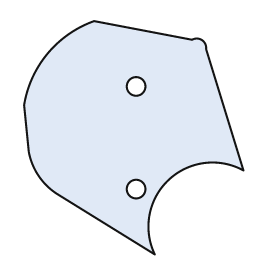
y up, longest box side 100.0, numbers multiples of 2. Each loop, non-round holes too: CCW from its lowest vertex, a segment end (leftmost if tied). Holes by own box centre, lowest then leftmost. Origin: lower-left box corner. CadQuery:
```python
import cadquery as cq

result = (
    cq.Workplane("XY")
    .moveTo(56.0, 0.0)
    .threePointArc((62.0, 32.0), (94.0, 36.0))
    .lineTo(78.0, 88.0)
    .threePointArc((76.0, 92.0), (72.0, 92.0))
    .lineTo(30.0, 100.0)
    .threePointArc((10.0, 86.0), (0.0, 64.0))
    .lineTo(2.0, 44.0)
    .threePointArc((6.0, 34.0), (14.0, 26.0))
    .close()
    .moveTo(48.0, 28.0)
    .circle(4.0)
    .moveTo(48.0, 72.0)
    .circle(4.0)
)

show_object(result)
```